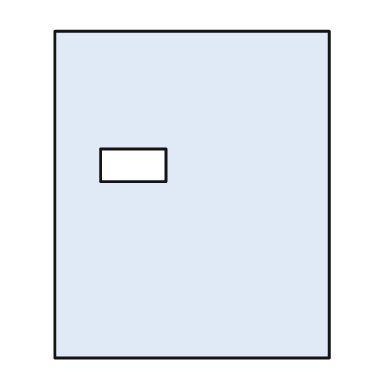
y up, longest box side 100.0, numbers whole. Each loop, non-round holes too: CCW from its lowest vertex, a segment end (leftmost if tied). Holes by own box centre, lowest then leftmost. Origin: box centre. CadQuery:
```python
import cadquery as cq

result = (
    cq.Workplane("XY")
    .moveTo(-42.0, -50.0)
    .lineTo(42.0, -50.0)
    .lineTo(42.0, 50.0)
    .lineTo(-42.0, 50.0)
    .close()
    .moveTo(-28.0, 4.0)
    .lineTo(-8.0, 4.0)
    .lineTo(-8.0, 14.0)
    .lineTo(-28.0, 14.0)
    .close()
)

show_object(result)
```